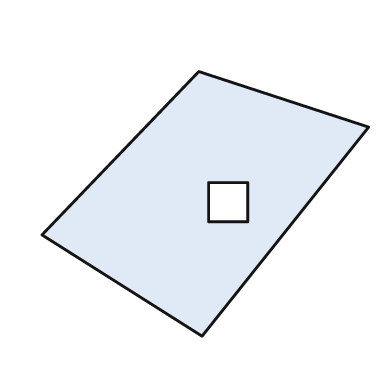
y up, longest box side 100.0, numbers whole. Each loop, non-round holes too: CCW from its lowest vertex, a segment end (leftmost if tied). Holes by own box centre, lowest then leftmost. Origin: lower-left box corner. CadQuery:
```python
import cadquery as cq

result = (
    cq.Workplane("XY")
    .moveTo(49.0, 0.0)
    .lineTo(100.0, 64.0)
    .lineTo(48.0, 81.0)
    .lineTo(0.0, 31.0)
    .close()
    .moveTo(51.0, 35.0)
    .lineTo(63.0, 35.0)
    .lineTo(63.0, 47.0)
    .lineTo(51.0, 47.0)
    .close()
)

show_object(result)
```